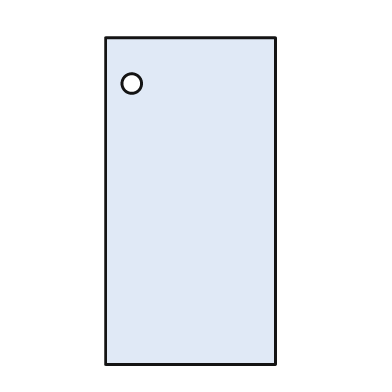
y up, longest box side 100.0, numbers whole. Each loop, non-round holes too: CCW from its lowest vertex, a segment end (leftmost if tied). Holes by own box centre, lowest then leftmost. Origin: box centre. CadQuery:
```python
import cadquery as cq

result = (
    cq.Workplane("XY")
    .moveTo(-26.0, -50.0)
    .lineTo(26.0, -50.0)
    .lineTo(26.0, 50.0)
    .lineTo(-26.0, 50.0)
    .close()
    .moveTo(-18.0, 36.0)
    .circle(3.0)
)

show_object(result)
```